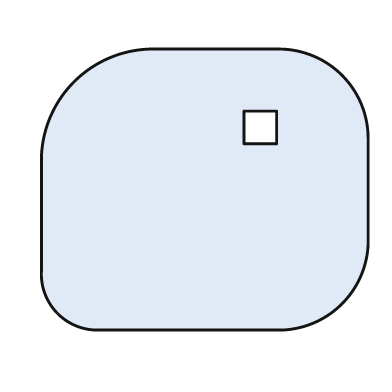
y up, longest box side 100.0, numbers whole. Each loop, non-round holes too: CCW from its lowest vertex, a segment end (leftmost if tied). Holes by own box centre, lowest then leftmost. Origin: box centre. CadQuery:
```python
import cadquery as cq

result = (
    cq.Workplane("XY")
    .moveTo(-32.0, -43.0)
    .lineTo(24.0, -43.0)
    .threePointArc((42.0, -35.0), (50.0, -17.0))
    .lineTo(50.0, 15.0)
    .threePointArc((42.0, 35.0), (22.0, 43.0))
    .lineTo(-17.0, 43.0)
    .threePointArc((-40.0, 33.0), (-50.0, 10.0))
    .lineTo(-50.0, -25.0)
    .threePointArc((-45.0, -38.0), (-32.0, -43.0))
    .close()
    .moveTo(12.0, 14.0)
    .lineTo(22.0, 14.0)
    .lineTo(22.0, 24.0)
    .lineTo(12.0, 24.0)
    .close()
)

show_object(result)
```